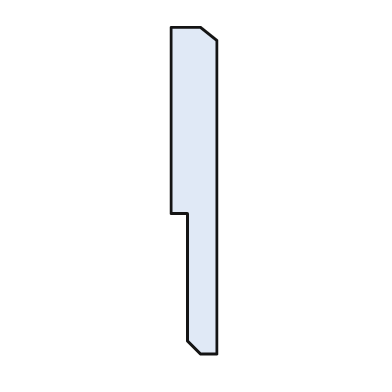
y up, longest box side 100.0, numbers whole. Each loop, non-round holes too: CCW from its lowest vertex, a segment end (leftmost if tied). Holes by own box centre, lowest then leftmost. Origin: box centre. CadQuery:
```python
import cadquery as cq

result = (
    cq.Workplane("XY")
    .moveTo(2.0, -50.0)
    .lineTo(7.0, -50.0)
    .lineTo(7.0, 46.0)
    .lineTo(2.0, 50.0)
    .lineTo(-7.0, 50.0)
    .lineTo(-7.0, -7.0)
    .lineTo(-2.0, -7.0)
    .lineTo(-2.0, -46.0)
    .close()
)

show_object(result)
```